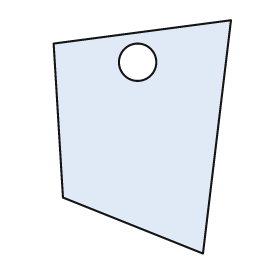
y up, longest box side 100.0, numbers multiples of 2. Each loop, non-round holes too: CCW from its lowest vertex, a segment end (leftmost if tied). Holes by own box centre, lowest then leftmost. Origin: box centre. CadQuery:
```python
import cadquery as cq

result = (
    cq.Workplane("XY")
    .moveTo(26.0, -50.0)
    .lineTo(38.0, 50.0)
    .lineTo(-38.0, 40.0)
    .lineTo(-34.0, -26.0)
    .close()
    .moveTo(-2.0, 32.0)
    .circle(8.0)
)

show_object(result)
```